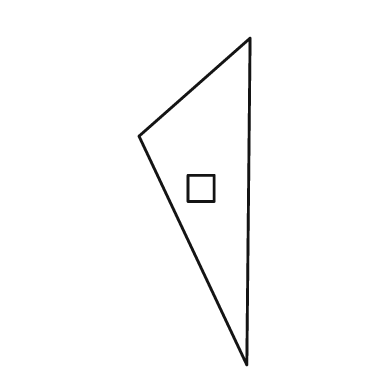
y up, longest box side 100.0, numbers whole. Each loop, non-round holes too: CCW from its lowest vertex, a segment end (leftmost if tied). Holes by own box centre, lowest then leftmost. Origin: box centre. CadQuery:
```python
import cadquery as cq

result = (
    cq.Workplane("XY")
    .moveTo(16.0, -50.0)
    .lineTo(17.0, 50.0)
    .lineTo(-17.0, 20.0)
    .close()
    .moveTo(-2.0, 0.0)
    .lineTo(6.0, 0.0)
    .lineTo(6.0, 8.0)
    .lineTo(-2.0, 8.0)
    .close()
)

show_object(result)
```